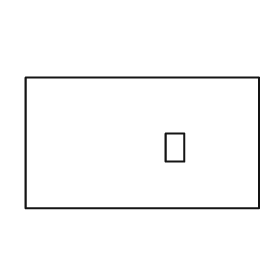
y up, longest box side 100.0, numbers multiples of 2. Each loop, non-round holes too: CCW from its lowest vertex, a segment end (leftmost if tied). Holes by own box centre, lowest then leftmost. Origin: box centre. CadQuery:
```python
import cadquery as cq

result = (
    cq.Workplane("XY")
    .moveTo(-50.0, -28.0)
    .lineTo(50.0, -28.0)
    .lineTo(50.0, 28.0)
    .lineTo(-50.0, 28.0)
    .close()
    .moveTo(10.0, -8.0)
    .lineTo(18.0, -8.0)
    .lineTo(18.0, 4.0)
    .lineTo(10.0, 4.0)
    .close()
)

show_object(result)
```